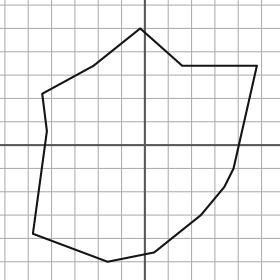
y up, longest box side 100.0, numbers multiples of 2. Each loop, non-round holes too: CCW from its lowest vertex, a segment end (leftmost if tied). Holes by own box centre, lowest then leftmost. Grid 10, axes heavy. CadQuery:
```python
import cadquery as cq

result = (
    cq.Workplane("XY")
    .moveTo(-16.0, -50.0)
    .lineTo(4.0, -46.0)
    .lineTo(24.0, -30.0)
    .lineTo(34.0, -18.0)
    .lineTo(38.0, -10.0)
    .lineTo(48.0, 34.0)
    .lineTo(16.0, 34.0)
    .lineTo(-2.0, 50.0)
    .lineTo(-22.0, 34.0)
    .lineTo(-44.0, 22.0)
    .lineTo(-42.0, 6.0)
    .lineTo(-48.0, -38.0)
    .close()
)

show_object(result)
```